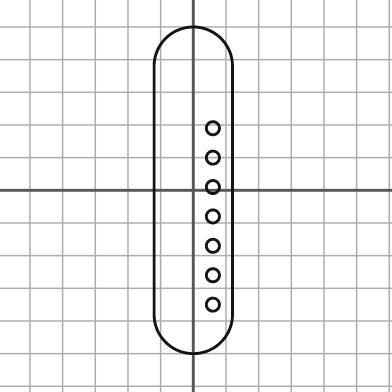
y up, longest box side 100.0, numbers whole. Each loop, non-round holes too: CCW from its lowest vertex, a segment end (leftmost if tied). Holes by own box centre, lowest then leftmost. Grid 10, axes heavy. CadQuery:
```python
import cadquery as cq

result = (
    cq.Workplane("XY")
    .moveTo(-12.0, -38.0)
    .threePointArc((0.0, -50.0), (12.0, -38.0))
    .lineTo(12.0, 38.0)
    .threePointArc((0.0, 50.0), (-12.0, 38.0))
    .close()
    .moveTo(6.0, -35.0)
    .circle(2.0)
    .moveTo(6.0, -26.0)
    .circle(2.0)
    .moveTo(6.0, -17.0)
    .circle(2.0)
    .moveTo(6.0, -8.0)
    .circle(2.0)
    .moveTo(6.0, 1.0)
    .circle(2.0)
    .moveTo(6.0, 10.0)
    .circle(2.0)
    .moveTo(6.0, 19.0)
    .circle(2.0)
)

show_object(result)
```